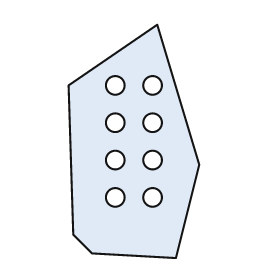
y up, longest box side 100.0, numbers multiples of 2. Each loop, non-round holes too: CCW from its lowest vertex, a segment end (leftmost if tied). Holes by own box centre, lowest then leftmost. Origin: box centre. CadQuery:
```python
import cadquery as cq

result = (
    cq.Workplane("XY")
    .moveTo(18.0, -50.0)
    .lineTo(28.0, -10.0)
    .lineTo(10.0, 50.0)
    .lineTo(-28.0, 24.0)
    .lineTo(-26.0, -40.0)
    .lineTo(-18.0, -48.0)
    .close()
    .moveTo(-8.0, -24.0)
    .circle(4.0)
    .moveTo(8.0, -24.0)
    .circle(4.0)
    .moveTo(-8.0, -8.0)
    .circle(4.0)
    .moveTo(8.0, -8.0)
    .circle(4.0)
    .moveTo(-8.0, 8.0)
    .circle(4.0)
    .moveTo(8.0, 8.0)
    .circle(4.0)
    .moveTo(-8.0, 24.0)
    .circle(4.0)
    .moveTo(8.0, 24.0)
    .circle(4.0)
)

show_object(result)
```